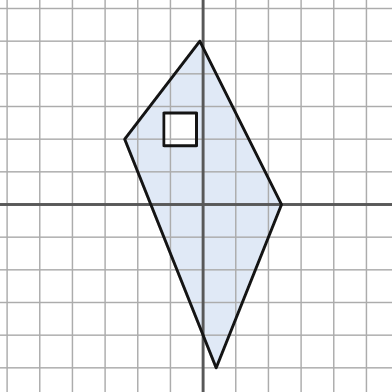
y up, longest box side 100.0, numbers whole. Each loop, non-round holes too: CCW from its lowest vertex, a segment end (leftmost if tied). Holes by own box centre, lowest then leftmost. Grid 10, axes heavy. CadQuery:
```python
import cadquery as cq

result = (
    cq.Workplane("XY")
    .moveTo(4.0, -50.0)
    .lineTo(24.0, 0.0)
    .lineTo(-1.0, 50.0)
    .lineTo(-24.0, 20.0)
    .close()
    .moveTo(-12.0, 18.0)
    .lineTo(-2.0, 18.0)
    .lineTo(-2.0, 28.0)
    .lineTo(-12.0, 28.0)
    .close()
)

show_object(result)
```